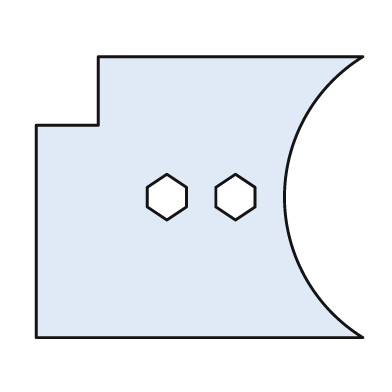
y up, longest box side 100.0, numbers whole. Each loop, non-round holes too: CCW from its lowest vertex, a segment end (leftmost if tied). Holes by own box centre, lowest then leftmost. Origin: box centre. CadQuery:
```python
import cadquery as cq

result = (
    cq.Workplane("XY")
    .moveTo(-50.0, -43.0)
    .lineTo(50.0, -43.0)
    .threePointArc((26.0, 0.0), (50.0, 43.0))
    .lineTo(-31.0, 43.0)
    .lineTo(-31.0, 22.0)
    .lineTo(-50.0, 22.0)
    .close()
    .moveTo(-10.0, -7.0)
    .lineTo(-4.0, -3.0)
    .lineTo(-4.0, 3.0)
    .lineTo(-10.0, 7.0)
    .lineTo(-16.0, 3.0)
    .lineTo(-16.0, -3.0)
    .close()
    .moveTo(11.0, -7.0)
    .lineTo(17.0, -3.0)
    .lineTo(17.0, 3.0)
    .lineTo(11.0, 7.0)
    .lineTo(5.0, 3.0)
    .lineTo(5.0, -3.0)
    .close()
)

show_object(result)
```